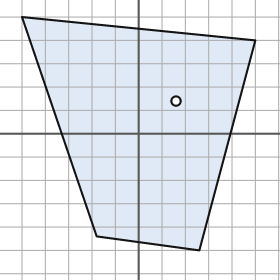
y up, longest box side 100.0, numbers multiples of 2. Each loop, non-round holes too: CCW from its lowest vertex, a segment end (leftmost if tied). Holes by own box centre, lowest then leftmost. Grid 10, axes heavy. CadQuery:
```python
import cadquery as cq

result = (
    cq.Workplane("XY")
    .moveTo(26.0, -50.0)
    .lineTo(50.0, 40.0)
    .lineTo(-50.0, 50.0)
    .lineTo(-18.0, -44.0)
    .close()
    .moveTo(16.0, 14.0)
    .circle(2.0)
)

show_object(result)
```